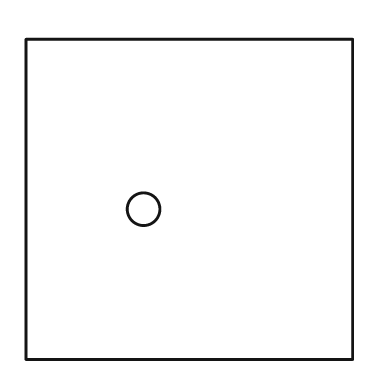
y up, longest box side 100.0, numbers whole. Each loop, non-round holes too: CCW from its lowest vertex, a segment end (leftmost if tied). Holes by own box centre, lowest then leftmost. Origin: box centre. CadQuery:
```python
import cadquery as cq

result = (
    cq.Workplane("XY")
    .moveTo(-50.0, -49.0)
    .lineTo(50.0, -49.0)
    .lineTo(50.0, 49.0)
    .lineTo(-50.0, 49.0)
    .close()
    .moveTo(-14.0, -3.0)
    .circle(5.0)
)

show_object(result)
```